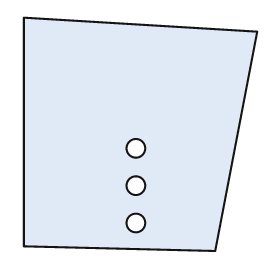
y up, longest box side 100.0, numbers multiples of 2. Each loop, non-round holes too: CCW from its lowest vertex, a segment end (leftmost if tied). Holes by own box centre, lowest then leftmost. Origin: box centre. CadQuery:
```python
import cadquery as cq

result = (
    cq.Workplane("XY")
    .moveTo(32.0, -50.0)
    .lineTo(50.0, 44.0)
    .lineTo(-50.0, 50.0)
    .lineTo(-50.0, -48.0)
    .close()
    .moveTo(-2.0, -38.0)
    .circle(4.0)
    .moveTo(-2.0, -22.0)
    .circle(4.0)
    .moveTo(-2.0, -6.0)
    .circle(4.0)
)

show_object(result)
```